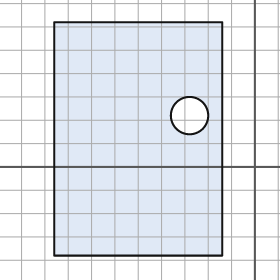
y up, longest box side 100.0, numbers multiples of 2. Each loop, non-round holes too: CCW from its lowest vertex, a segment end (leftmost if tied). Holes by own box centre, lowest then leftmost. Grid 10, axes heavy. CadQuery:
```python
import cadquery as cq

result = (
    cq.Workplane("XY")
    .moveTo(-86.0, -38.0)
    .lineTo(-14.0, -38.0)
    .lineTo(-14.0, 62.0)
    .lineTo(-86.0, 62.0)
    .close()
    .moveTo(-28.0, 22.0)
    .circle(8.0)
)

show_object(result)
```